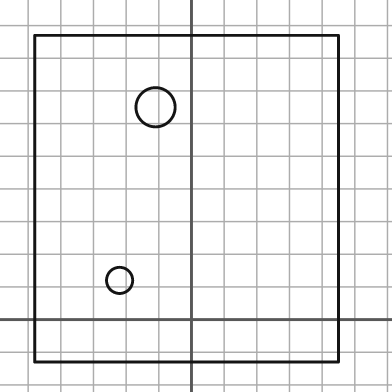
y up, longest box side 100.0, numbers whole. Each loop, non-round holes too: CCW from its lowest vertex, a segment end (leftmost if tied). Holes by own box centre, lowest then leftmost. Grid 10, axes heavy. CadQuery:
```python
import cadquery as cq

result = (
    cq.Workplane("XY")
    .moveTo(-48.0, -13.0)
    .lineTo(45.0, -13.0)
    .lineTo(45.0, 87.0)
    .lineTo(-48.0, 87.0)
    .close()
    .moveTo(-22.0, 12.0)
    .circle(4.0)
    .moveTo(-11.0, 65.0)
    .circle(6.0)
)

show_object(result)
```